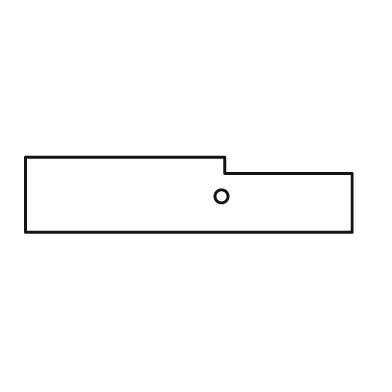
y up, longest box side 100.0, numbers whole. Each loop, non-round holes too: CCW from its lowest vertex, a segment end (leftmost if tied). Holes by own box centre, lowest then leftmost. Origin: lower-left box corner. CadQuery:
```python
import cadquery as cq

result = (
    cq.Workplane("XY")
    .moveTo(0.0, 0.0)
    .lineTo(100.0, 0.0)
    .lineTo(100.0, 18.0)
    .lineTo(61.0, 18.0)
    .lineTo(61.0, 23.0)
    .lineTo(0.0, 23.0)
    .close()
    .moveTo(60.0, 11.0)
    .circle(2.0)
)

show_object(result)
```